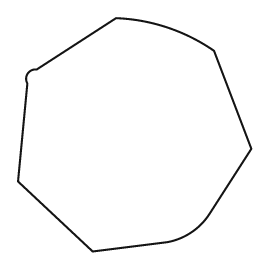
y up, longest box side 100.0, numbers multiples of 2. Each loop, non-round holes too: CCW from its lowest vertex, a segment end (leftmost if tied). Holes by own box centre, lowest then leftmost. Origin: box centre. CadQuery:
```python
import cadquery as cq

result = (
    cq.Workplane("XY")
    .moveTo(-18.0, -50.0)
    .lineTo(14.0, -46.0)
    .threePointArc((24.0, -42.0), (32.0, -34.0))
    .lineTo(50.0, -6.0)
    .lineTo(34.0, 36.0)
    .threePointArc((14.0, 46.0), (-8.0, 50.0))
    .lineTo(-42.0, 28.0)
    .threePointArc((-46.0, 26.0), (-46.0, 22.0))
    .lineTo(-50.0, -20.0)
    .close()
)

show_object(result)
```